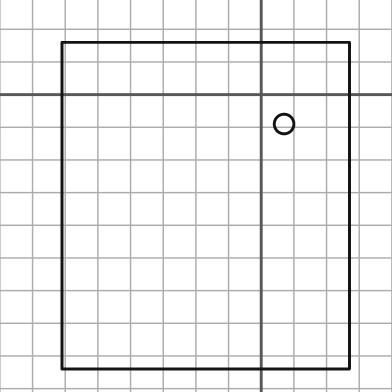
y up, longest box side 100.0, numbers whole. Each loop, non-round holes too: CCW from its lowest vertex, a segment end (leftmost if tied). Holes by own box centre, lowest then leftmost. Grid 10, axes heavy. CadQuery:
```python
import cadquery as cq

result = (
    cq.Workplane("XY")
    .moveTo(-61.0, -84.0)
    .lineTo(27.0, -84.0)
    .lineTo(27.0, 16.0)
    .lineTo(-61.0, 16.0)
    .close()
    .moveTo(7.0, -9.0)
    .circle(3.0)
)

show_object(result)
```